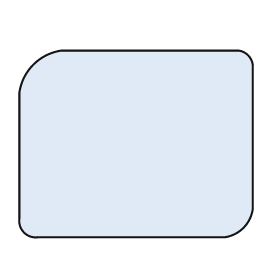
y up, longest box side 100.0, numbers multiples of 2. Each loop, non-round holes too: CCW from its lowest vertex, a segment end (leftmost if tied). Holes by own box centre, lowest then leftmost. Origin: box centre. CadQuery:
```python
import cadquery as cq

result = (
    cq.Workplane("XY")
    .moveTo(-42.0, -40.0)
    .lineTo(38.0, -40.0)
    .threePointArc((46.0, -36.0), (50.0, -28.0))
    .lineTo(50.0, 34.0)
    .threePointArc((48.0, 38.0), (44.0, 40.0))
    .lineTo(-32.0, 40.0)
    .threePointArc((-44.0, 34.0), (-50.0, 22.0))
    .lineTo(-50.0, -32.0)
    .threePointArc((-48.0, -38.0), (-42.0, -40.0))
    .close()
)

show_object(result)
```